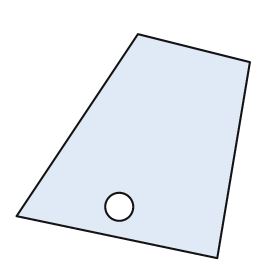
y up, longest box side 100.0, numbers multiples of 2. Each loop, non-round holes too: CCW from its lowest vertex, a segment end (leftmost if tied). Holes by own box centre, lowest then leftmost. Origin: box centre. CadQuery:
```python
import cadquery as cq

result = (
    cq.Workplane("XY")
    .moveTo(36.0, -48.0)
    .lineTo(50.0, 36.0)
    .lineTo(2.0, 48.0)
    .lineTo(-50.0, -30.0)
    .close()
    .moveTo(-6.0, -26.0)
    .circle(6.0)
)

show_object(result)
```